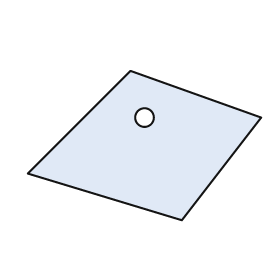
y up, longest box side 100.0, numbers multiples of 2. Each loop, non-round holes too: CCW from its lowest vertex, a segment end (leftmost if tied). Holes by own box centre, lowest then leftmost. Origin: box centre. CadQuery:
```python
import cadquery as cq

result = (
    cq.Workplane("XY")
    .moveTo(16.0, -32.0)
    .lineTo(50.0, 12.0)
    .lineTo(-6.0, 32.0)
    .lineTo(-50.0, -12.0)
    .close()
    .moveTo(0.0, 12.0)
    .circle(4.0)
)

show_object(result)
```